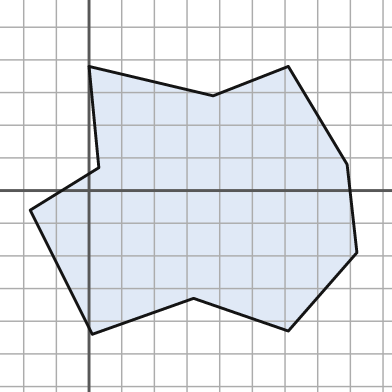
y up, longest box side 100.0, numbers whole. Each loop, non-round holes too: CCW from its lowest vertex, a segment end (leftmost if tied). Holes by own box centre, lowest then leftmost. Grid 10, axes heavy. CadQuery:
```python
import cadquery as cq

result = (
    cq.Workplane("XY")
    .moveTo(1.0, -44.0)
    .lineTo(32.0, -33.0)
    .lineTo(61.0, -43.0)
    .lineTo(82.0, -19.0)
    .lineTo(79.0, 8.0)
    .lineTo(61.0, 38.0)
    .lineTo(38.0, 29.0)
    .lineTo(0.0, 38.0)
    .lineTo(3.0, 7.0)
    .lineTo(-18.0, -6.0)
    .close()
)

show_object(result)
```